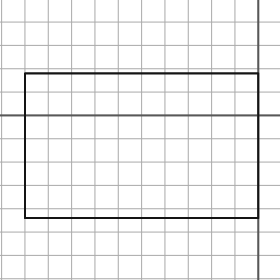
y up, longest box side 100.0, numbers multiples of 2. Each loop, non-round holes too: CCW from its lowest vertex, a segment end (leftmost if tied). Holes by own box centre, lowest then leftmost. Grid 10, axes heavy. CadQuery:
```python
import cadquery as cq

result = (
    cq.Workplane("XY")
    .moveTo(-100.0, -44.0)
    .lineTo(0.0, -44.0)
    .lineTo(0.0, 18.0)
    .lineTo(-100.0, 18.0)
    .close()
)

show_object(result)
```